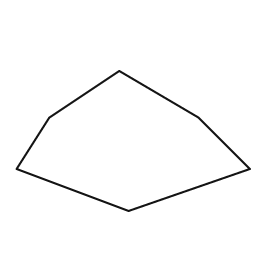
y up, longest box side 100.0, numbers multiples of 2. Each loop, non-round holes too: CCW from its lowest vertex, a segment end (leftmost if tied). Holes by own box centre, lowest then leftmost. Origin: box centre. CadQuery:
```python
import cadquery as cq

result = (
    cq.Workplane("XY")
    .moveTo(-2.0, -30.0)
    .lineTo(50.0, -12.0)
    .lineTo(28.0, 10.0)
    .lineTo(-6.0, 30.0)
    .lineTo(-36.0, 10.0)
    .lineTo(-50.0, -12.0)
    .close()
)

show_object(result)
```